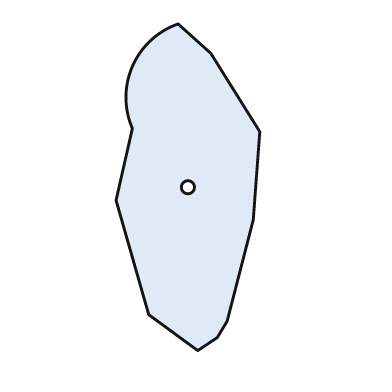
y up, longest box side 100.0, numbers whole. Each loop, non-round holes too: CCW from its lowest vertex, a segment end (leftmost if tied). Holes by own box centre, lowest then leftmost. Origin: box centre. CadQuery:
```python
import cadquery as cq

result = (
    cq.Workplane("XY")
    .moveTo(3.0, -50.0)
    .lineTo(9.0, -46.0)
    .lineTo(12.0, -41.0)
    .lineTo(20.0, -10.0)
    .lineTo(22.0, 17.0)
    .lineTo(7.0, 41.0)
    .lineTo(-3.0, 50.0)
    .threePointArc((-17.0, 37.0), (-17.0, 18.0))
    .lineTo(-22.0, -4.0)
    .lineTo(-12.0, -39.0)
    .close()
    .moveTo(0.0, 0.0)
    .circle(2.0)
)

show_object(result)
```